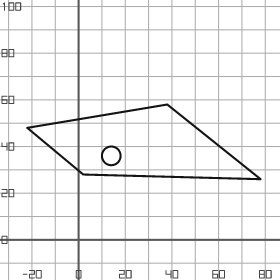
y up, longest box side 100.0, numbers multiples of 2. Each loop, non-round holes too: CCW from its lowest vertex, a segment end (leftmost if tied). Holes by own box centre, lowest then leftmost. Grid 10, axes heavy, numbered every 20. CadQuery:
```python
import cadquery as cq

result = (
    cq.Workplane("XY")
    .moveTo(78.0, 26.0)
    .lineTo(38.0, 58.0)
    .lineTo(-22.0, 48.0)
    .lineTo(2.0, 28.0)
    .close()
    .moveTo(14.0, 36.0)
    .circle(4.0)
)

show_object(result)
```